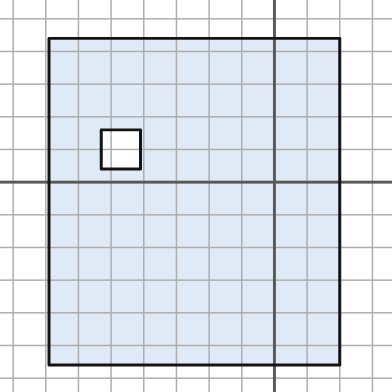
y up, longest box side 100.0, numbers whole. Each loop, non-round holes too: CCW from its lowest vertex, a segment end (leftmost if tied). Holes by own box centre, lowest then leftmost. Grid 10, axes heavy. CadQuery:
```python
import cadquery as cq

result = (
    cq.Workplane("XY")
    .moveTo(-69.0, -56.0)
    .lineTo(20.0, -56.0)
    .lineTo(20.0, 44.0)
    .lineTo(-69.0, 44.0)
    .close()
    .moveTo(-53.0, 4.0)
    .lineTo(-41.0, 4.0)
    .lineTo(-41.0, 16.0)
    .lineTo(-53.0, 16.0)
    .close()
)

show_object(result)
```